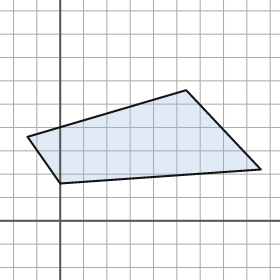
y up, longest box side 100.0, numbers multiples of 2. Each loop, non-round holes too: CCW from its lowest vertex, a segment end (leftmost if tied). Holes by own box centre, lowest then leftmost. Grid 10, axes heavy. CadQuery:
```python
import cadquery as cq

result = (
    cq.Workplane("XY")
    .moveTo(0.0, 16.0)
    .lineTo(86.0, 22.0)
    .lineTo(54.0, 56.0)
    .lineTo(-14.0, 36.0)
    .close()
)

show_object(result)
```